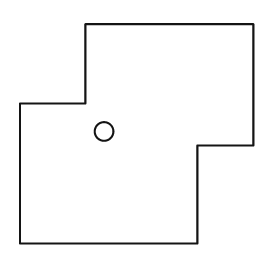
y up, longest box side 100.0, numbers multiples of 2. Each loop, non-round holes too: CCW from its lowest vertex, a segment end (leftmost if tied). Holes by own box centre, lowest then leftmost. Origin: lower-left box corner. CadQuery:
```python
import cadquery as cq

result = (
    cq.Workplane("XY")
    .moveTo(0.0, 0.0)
    .lineTo(76.0, 0.0)
    .lineTo(76.0, 42.0)
    .lineTo(100.0, 42.0)
    .lineTo(100.0, 94.0)
    .lineTo(28.0, 94.0)
    .lineTo(28.0, 60.0)
    .lineTo(0.0, 60.0)
    .close()
    .moveTo(36.0, 48.0)
    .circle(4.0)
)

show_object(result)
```